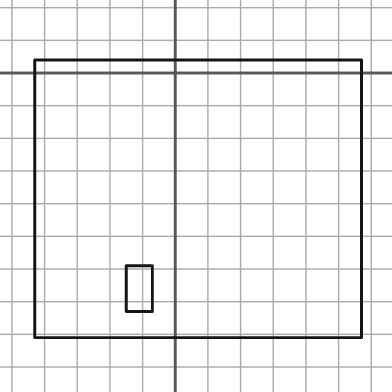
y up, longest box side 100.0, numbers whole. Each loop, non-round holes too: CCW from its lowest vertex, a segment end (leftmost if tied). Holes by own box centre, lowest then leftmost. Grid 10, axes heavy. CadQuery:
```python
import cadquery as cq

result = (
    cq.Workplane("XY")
    .moveTo(-43.0, -81.0)
    .lineTo(57.0, -81.0)
    .lineTo(57.0, 4.0)
    .lineTo(-43.0, 4.0)
    .close()
    .moveTo(-15.0, -73.0)
    .lineTo(-7.0, -73.0)
    .lineTo(-7.0, -59.0)
    .lineTo(-15.0, -59.0)
    .close()
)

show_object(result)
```